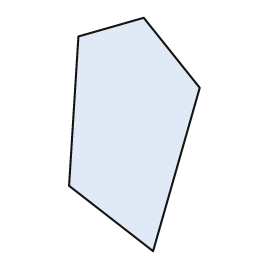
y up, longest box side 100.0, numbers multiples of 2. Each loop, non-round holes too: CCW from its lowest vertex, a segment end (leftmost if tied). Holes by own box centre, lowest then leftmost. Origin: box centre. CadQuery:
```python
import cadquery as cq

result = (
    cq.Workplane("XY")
    .moveTo(8.0, -50.0)
    .lineTo(28.0, 20.0)
    .lineTo(4.0, 50.0)
    .lineTo(-24.0, 42.0)
    .lineTo(-28.0, -22.0)
    .close()
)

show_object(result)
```